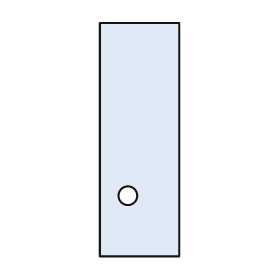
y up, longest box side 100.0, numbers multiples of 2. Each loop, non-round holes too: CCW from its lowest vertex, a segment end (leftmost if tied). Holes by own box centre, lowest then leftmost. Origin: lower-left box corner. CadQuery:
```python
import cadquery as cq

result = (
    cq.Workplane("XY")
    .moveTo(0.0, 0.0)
    .lineTo(34.0, 0.0)
    .lineTo(34.0, 100.0)
    .lineTo(0.0, 100.0)
    .close()
    .moveTo(12.0, 26.0)
    .circle(4.0)
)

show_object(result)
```